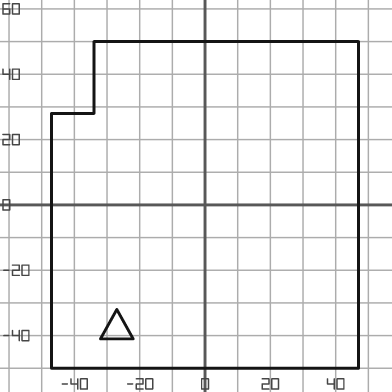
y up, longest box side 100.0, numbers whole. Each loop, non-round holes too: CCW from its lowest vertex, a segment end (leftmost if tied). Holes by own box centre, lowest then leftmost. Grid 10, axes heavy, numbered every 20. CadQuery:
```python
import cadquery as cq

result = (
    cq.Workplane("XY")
    .moveTo(-47.0, -50.0)
    .lineTo(47.0, -50.0)
    .lineTo(47.0, 50.0)
    .lineTo(-34.0, 50.0)
    .lineTo(-34.0, 28.0)
    .lineTo(-47.0, 28.0)
    .close()
    .moveTo(-32.0, -41.0)
    .lineTo(-22.0, -41.0)
    .lineTo(-27.0, -32.0)
    .close()
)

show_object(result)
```